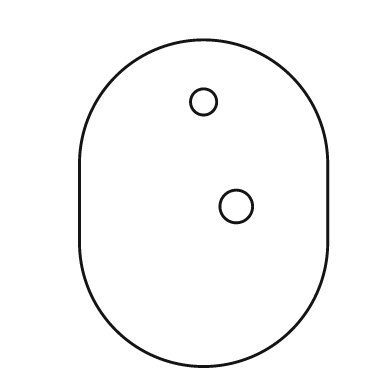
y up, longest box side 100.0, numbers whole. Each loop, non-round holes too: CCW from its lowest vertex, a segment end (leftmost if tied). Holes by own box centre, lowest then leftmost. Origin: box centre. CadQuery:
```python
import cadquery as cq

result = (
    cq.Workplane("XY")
    .moveTo(-38.0, -12.0)
    .threePointArc((0.0, -50.0), (38.0, -12.0))
    .lineTo(38.0, 12.0)
    .threePointArc((0.0, 50.0), (-38.0, 12.0))
    .close()
    .moveTo(10.0, -1.0)
    .circle(5.0)
    .moveTo(0.0, 31.0)
    .circle(4.0)
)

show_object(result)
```